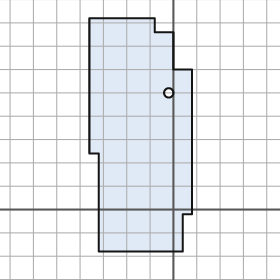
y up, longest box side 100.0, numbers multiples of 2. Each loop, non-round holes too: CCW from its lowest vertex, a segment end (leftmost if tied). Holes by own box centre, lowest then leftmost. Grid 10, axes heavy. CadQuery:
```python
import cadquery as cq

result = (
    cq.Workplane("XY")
    .moveTo(-32.0, -18.0)
    .lineTo(4.0, -18.0)
    .lineTo(4.0, -2.0)
    .lineTo(8.0, -2.0)
    .lineTo(8.0, 60.0)
    .lineTo(0.0, 60.0)
    .lineTo(0.0, 76.0)
    .lineTo(-8.0, 76.0)
    .lineTo(-8.0, 82.0)
    .lineTo(-36.0, 82.0)
    .lineTo(-36.0, 24.0)
    .lineTo(-32.0, 24.0)
    .close()
    .moveTo(-2.0, 50.0)
    .circle(2.0)
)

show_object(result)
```